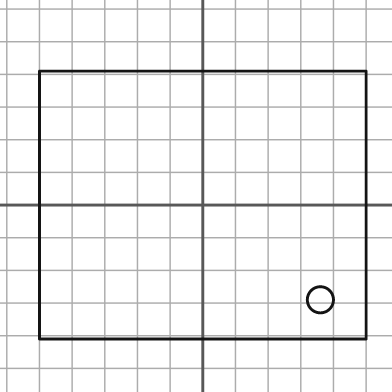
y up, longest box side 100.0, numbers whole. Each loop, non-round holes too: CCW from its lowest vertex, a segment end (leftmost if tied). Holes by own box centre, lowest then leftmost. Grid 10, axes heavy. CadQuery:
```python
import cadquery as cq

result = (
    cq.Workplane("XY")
    .moveTo(-50.0, -41.0)
    .lineTo(50.0, -41.0)
    .lineTo(50.0, 41.0)
    .lineTo(-50.0, 41.0)
    .close()
    .moveTo(36.0, -29.0)
    .circle(4.0)
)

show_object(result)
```